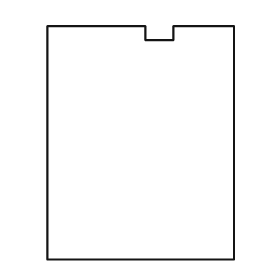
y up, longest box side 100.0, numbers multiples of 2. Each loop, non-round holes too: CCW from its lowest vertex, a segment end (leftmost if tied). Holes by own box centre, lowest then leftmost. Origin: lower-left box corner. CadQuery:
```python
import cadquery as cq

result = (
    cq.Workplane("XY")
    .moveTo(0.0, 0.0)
    .lineTo(80.0, 0.0)
    .lineTo(80.0, 100.0)
    .lineTo(54.0, 100.0)
    .lineTo(54.0, 94.0)
    .lineTo(42.0, 94.0)
    .lineTo(42.0, 100.0)
    .lineTo(0.0, 100.0)
    .close()
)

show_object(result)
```